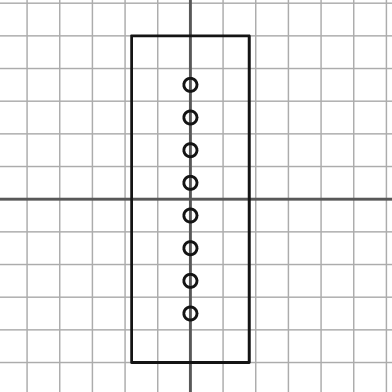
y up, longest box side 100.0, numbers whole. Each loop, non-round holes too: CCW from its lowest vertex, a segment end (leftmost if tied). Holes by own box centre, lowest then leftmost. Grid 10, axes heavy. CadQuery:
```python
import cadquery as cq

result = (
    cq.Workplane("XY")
    .moveTo(-18.0, -50.0)
    .lineTo(18.0, -50.0)
    .lineTo(18.0, 50.0)
    .lineTo(-18.0, 50.0)
    .close()
    .moveTo(0.0, -35.0)
    .circle(2.0)
    .moveTo(0.0, -25.0)
    .circle(2.0)
    .moveTo(0.0, -15.0)
    .circle(2.0)
    .moveTo(0.0, -5.0)
    .circle(2.0)
    .moveTo(0.0, 5.0)
    .circle(2.0)
    .moveTo(0.0, 15.0)
    .circle(2.0)
    .moveTo(0.0, 25.0)
    .circle(2.0)
    .moveTo(0.0, 35.0)
    .circle(2.0)
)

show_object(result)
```